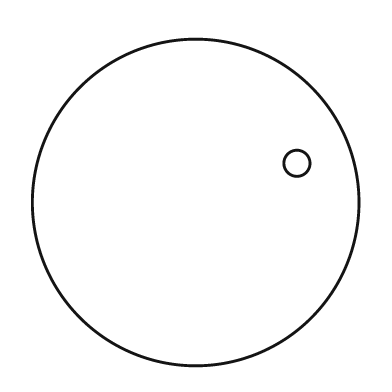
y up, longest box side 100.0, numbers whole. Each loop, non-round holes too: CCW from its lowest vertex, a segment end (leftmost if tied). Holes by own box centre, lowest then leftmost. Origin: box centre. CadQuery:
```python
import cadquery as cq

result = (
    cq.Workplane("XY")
    .moveTo(0.0, 0.0)
    .circle(50.0)
    .moveTo(31.0, 12.0)
    .circle(4.0)
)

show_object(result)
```